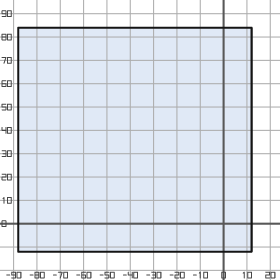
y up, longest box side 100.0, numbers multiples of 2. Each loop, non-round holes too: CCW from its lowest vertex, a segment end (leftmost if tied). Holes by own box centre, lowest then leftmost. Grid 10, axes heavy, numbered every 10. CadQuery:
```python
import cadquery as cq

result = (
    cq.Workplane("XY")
    .moveTo(-88.0, -12.0)
    .lineTo(12.0, -12.0)
    .lineTo(12.0, 84.0)
    .lineTo(-88.0, 84.0)
    .close()
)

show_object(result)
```